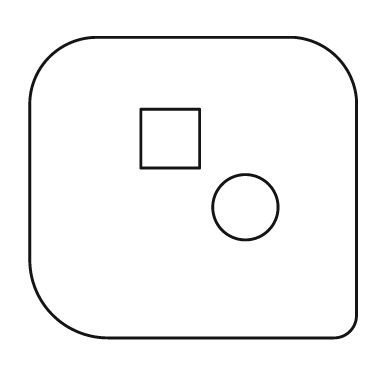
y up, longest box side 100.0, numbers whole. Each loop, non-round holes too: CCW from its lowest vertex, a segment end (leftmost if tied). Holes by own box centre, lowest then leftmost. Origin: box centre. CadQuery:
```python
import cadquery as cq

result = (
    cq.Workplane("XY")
    .moveTo(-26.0, -46.0)
    .lineTo(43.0, -46.0)
    .threePointArc((48.0, -44.0), (50.0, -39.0))
    .lineTo(50.0, 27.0)
    .threePointArc((44.0, 40.0), (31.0, 46.0))
    .lineTo(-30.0, 46.0)
    .threePointArc((-44.0, 40.0), (-50.0, 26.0))
    .lineTo(-50.0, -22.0)
    .threePointArc((-43.0, -39.0), (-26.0, -46.0))
    .close()
    .moveTo(16.0, -6.0)
    .circle(10.0)
    .moveTo(-16.0, 6.0)
    .lineTo(2.0, 6.0)
    .lineTo(2.0, 24.0)
    .lineTo(-16.0, 24.0)
    .close()
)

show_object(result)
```